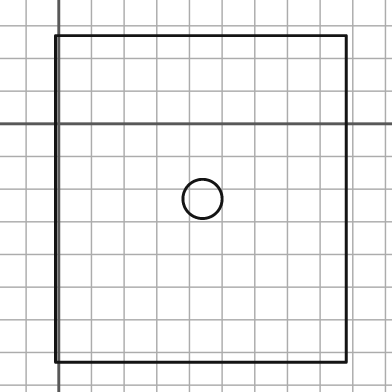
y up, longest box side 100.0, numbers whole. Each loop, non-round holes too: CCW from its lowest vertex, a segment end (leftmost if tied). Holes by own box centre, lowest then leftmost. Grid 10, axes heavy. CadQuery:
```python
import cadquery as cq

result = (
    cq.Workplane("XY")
    .moveTo(-1.0, -73.0)
    .lineTo(88.0, -73.0)
    .lineTo(88.0, 27.0)
    .lineTo(-1.0, 27.0)
    .close()
    .moveTo(44.0, -23.0)
    .circle(6.0)
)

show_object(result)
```